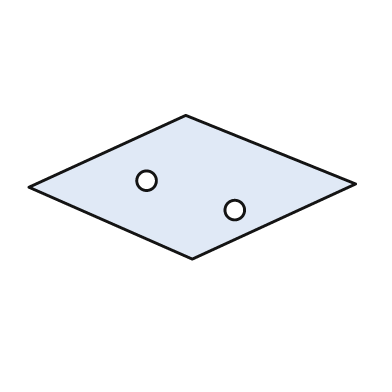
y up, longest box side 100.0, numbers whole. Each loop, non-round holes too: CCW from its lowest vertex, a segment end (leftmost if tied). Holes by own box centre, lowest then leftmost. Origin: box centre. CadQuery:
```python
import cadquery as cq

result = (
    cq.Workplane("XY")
    .moveTo(0.0, -22.0)
    .lineTo(50.0, 1.0)
    .lineTo(-2.0, 22.0)
    .lineTo(-50.0, 0.0)
    .close()
    .moveTo(13.0, -7.0)
    .circle(3.0)
    .moveTo(-14.0, 2.0)
    .circle(3.0)
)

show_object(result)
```